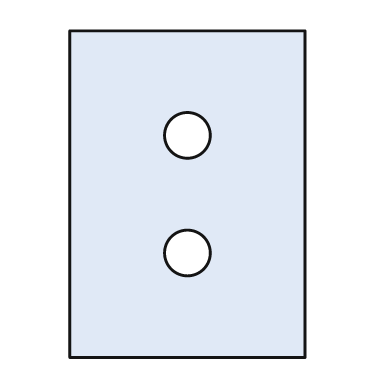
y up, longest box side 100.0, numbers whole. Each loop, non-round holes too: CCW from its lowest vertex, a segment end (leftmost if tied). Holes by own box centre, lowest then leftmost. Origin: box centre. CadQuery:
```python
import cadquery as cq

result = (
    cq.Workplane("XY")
    .moveTo(-36.0, -50.0)
    .lineTo(36.0, -50.0)
    .lineTo(36.0, 50.0)
    .lineTo(-36.0, 50.0)
    .close()
    .moveTo(0.0, -18.0)
    .circle(7.0)
    .moveTo(0.0, 18.0)
    .circle(7.0)
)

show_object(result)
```